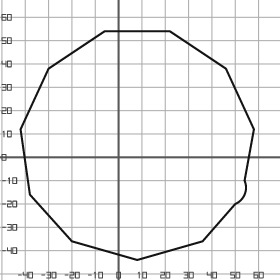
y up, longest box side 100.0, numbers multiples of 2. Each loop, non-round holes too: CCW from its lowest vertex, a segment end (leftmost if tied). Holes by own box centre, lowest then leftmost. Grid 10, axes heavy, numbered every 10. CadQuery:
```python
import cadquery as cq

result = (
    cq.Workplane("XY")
    .moveTo(8.0, -44.0)
    .lineTo(36.0, -36.0)
    .lineTo(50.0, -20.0)
    .threePointArc((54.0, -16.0), (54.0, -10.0))
    .lineTo(58.0, 12.0)
    .lineTo(46.0, 38.0)
    .lineTo(22.0, 54.0)
    .lineTo(-6.0, 54.0)
    .lineTo(-30.0, 38.0)
    .lineTo(-42.0, 12.0)
    .lineTo(-38.0, -16.0)
    .lineTo(-20.0, -36.0)
    .close()
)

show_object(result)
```